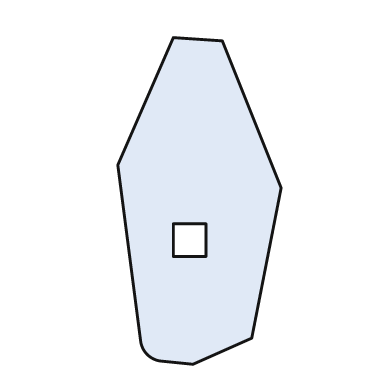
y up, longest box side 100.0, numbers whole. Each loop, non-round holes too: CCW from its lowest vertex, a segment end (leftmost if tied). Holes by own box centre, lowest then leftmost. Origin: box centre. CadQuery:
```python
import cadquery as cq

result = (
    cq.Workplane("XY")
    .moveTo(-2.0, -50.0)
    .lineTo(16.0, -42.0)
    .lineTo(25.0, 4.0)
    .lineTo(7.0, 49.0)
    .lineTo(-8.0, 50.0)
    .lineTo(-25.0, 11.0)
    .lineTo(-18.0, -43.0)
    .threePointArc((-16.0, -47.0), (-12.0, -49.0))
    .close()
    .moveTo(-8.0, -17.0)
    .lineTo(2.0, -17.0)
    .lineTo(2.0, -7.0)
    .lineTo(-8.0, -7.0)
    .close()
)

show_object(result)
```